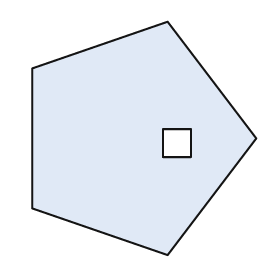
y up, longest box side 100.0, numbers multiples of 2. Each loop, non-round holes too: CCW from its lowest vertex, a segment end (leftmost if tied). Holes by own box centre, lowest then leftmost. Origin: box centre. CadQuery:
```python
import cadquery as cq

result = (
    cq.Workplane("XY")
    .moveTo(10.0, -50.0)
    .lineTo(48.0, 0.0)
    .lineTo(10.0, 50.0)
    .lineTo(-48.0, 30.0)
    .lineTo(-48.0, -30.0)
    .close()
    .moveTo(8.0, -8.0)
    .lineTo(20.0, -8.0)
    .lineTo(20.0, 4.0)
    .lineTo(8.0, 4.0)
    .close()
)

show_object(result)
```